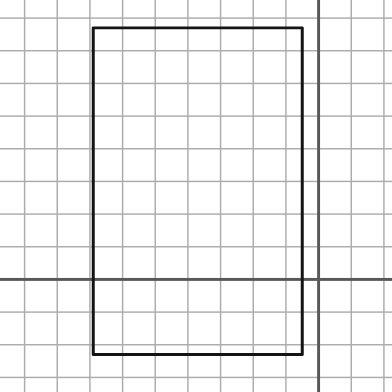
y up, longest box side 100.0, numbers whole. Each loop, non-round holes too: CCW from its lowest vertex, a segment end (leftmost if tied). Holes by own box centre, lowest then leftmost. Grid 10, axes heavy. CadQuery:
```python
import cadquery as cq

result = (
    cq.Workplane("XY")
    .moveTo(-69.0, -23.0)
    .lineTo(-5.0, -23.0)
    .lineTo(-5.0, 77.0)
    .lineTo(-69.0, 77.0)
    .close()
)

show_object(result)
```